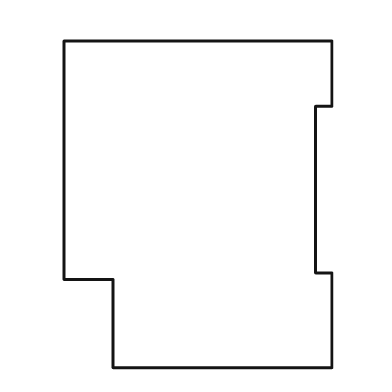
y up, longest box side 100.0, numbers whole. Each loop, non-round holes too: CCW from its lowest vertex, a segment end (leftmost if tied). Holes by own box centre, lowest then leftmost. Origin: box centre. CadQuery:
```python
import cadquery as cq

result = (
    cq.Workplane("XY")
    .moveTo(-26.0, -50.0)
    .lineTo(41.0, -50.0)
    .lineTo(41.0, -21.0)
    .lineTo(36.0, -21.0)
    .lineTo(36.0, 30.0)
    .lineTo(41.0, 30.0)
    .lineTo(41.0, 50.0)
    .lineTo(-41.0, 50.0)
    .lineTo(-41.0, -23.0)
    .lineTo(-26.0, -23.0)
    .close()
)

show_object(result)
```